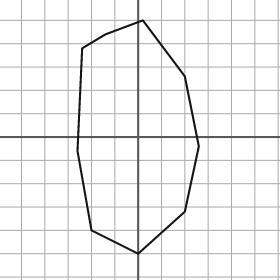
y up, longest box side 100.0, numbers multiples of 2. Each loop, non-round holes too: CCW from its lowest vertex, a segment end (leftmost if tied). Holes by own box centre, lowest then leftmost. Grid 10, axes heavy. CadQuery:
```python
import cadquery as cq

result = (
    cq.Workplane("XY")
    .moveTo(0.0, -50.0)
    .lineTo(20.0, -32.0)
    .lineTo(26.0, -4.0)
    .lineTo(20.0, 26.0)
    .lineTo(2.0, 50.0)
    .lineTo(-14.0, 44.0)
    .lineTo(-24.0, 38.0)
    .lineTo(-26.0, -6.0)
    .lineTo(-20.0, -40.0)
    .close()
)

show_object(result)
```